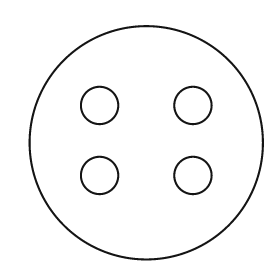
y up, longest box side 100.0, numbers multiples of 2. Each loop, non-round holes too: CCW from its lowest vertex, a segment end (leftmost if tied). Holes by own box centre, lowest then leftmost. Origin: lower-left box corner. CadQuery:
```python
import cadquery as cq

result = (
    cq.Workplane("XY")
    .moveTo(50.0, 50.0)
    .circle(50.0)
    .moveTo(30.0, 36.0)
    .circle(8.0)
    .moveTo(70.0, 36.0)
    .circle(8.0)
    .moveTo(30.0, 66.0)
    .circle(8.0)
    .moveTo(70.0, 66.0)
    .circle(8.0)
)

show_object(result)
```